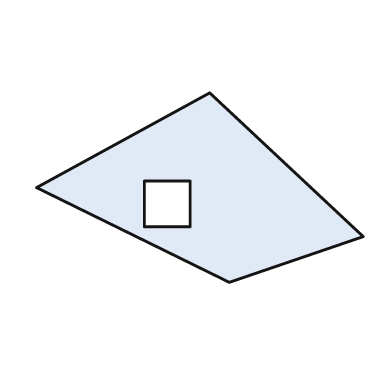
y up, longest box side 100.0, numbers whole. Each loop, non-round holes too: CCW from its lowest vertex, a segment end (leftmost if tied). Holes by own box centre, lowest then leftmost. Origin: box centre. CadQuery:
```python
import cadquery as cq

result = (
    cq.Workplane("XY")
    .moveTo(9.0, -29.0)
    .lineTo(50.0, -15.0)
    .lineTo(3.0, 29.0)
    .lineTo(-50.0, 0.0)
    .close()
    .moveTo(-17.0, -12.0)
    .lineTo(-3.0, -12.0)
    .lineTo(-3.0, 2.0)
    .lineTo(-17.0, 2.0)
    .close()
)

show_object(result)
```